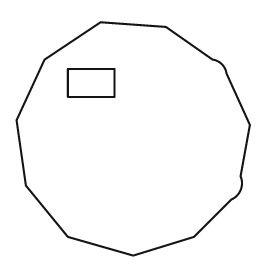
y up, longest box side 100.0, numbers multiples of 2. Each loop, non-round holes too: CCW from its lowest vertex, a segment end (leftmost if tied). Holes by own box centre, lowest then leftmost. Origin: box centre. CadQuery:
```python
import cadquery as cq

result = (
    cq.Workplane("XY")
    .moveTo(0.0, -50.0)
    .lineTo(26.0, -42.0)
    .lineTo(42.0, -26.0)
    .threePointArc((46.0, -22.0), (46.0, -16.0))
    .lineTo(50.0, 6.0)
    .lineTo(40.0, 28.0)
    .threePointArc((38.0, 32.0), (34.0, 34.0))
    .lineTo(14.0, 48.0)
    .lineTo(-14.0, 50.0)
    .lineTo(-38.0, 34.0)
    .lineTo(-50.0, 8.0)
    .lineTo(-46.0, -20.0)
    .lineTo(-28.0, -42.0)
    .close()
    .moveTo(-28.0, 18.0)
    .lineTo(-8.0, 18.0)
    .lineTo(-8.0, 30.0)
    .lineTo(-28.0, 30.0)
    .close()
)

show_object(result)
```